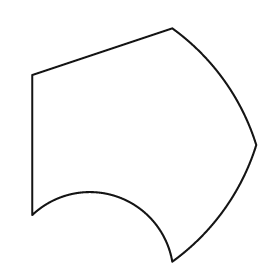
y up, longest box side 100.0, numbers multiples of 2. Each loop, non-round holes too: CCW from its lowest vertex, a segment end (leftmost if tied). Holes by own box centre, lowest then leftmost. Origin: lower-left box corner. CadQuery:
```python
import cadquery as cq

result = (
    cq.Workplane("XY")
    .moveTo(60.0, 0.0)
    .threePointArc((82.0, 22.0), (96.0, 50.0))
    .threePointArc((82.0, 78.0), (60.0, 100.0))
    .lineTo(0.0, 80.0)
    .lineTo(0.0, 20.0)
    .threePointArc((36.0, 28.0), (60.0, 0.0))
    .close()
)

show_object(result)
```